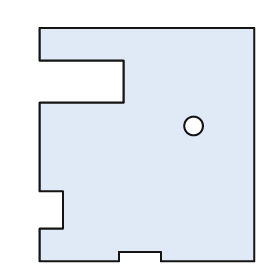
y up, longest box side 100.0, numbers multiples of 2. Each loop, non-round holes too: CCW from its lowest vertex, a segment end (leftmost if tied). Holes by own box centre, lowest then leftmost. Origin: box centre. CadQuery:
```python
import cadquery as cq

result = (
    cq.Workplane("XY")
    .moveTo(-46.0, -50.0)
    .lineTo(-12.0, -50.0)
    .lineTo(-12.0, -46.0)
    .lineTo(6.0, -46.0)
    .lineTo(6.0, -50.0)
    .lineTo(46.0, -50.0)
    .lineTo(46.0, 50.0)
    .lineTo(-46.0, 50.0)
    .lineTo(-46.0, 36.0)
    .lineTo(-10.0, 36.0)
    .lineTo(-10.0, 18.0)
    .lineTo(-46.0, 18.0)
    .lineTo(-46.0, -20.0)
    .lineTo(-36.0, -20.0)
    .lineTo(-36.0, -36.0)
    .lineTo(-46.0, -36.0)
    .close()
    .moveTo(20.0, 8.0)
    .circle(4.0)
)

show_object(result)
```